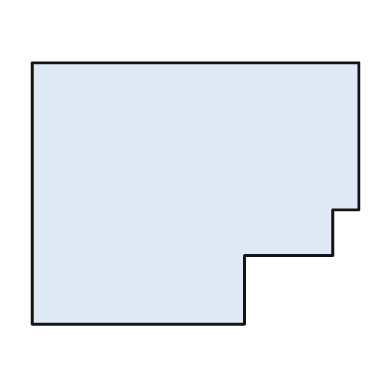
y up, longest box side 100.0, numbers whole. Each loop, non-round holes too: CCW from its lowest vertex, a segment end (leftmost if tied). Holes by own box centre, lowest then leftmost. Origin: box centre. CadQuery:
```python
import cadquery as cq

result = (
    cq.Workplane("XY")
    .moveTo(-50.0, -40.0)
    .lineTo(15.0, -40.0)
    .lineTo(15.0, -19.0)
    .lineTo(42.0, -19.0)
    .lineTo(42.0, -5.0)
    .lineTo(50.0, -5.0)
    .lineTo(50.0, 40.0)
    .lineTo(-50.0, 40.0)
    .close()
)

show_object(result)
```